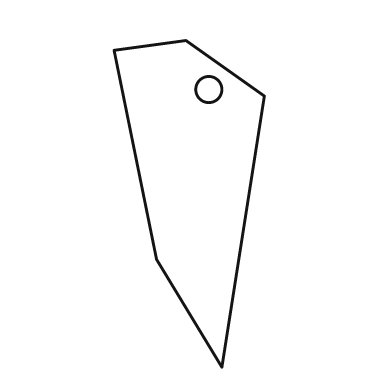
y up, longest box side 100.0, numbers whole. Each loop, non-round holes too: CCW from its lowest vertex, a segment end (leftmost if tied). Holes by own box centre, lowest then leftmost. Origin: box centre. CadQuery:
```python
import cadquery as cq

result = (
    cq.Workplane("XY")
    .moveTo(10.0, -50.0)
    .lineTo(23.0, 33.0)
    .lineTo(-1.0, 50.0)
    .lineTo(-23.0, 47.0)
    .lineTo(-10.0, -17.0)
    .close()
    .moveTo(6.0, 35.0)
    .circle(4.0)
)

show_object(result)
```